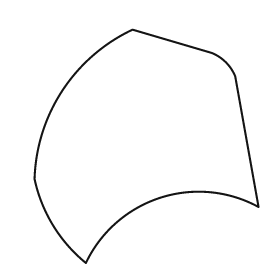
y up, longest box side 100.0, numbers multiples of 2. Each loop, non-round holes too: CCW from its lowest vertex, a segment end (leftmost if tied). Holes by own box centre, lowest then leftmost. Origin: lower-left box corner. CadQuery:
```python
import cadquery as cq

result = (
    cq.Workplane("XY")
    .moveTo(22.0, 0.0)
    .threePointArc((54.0, 28.0), (96.0, 24.0))
    .lineTo(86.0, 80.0)
    .threePointArc((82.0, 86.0), (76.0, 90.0))
    .lineTo(42.0, 100.0)
    .threePointArc((12.0, 74.0), (0.0, 36.0))
    .threePointArc((8.0, 16.0), (22.0, 0.0))
    .close()
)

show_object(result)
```